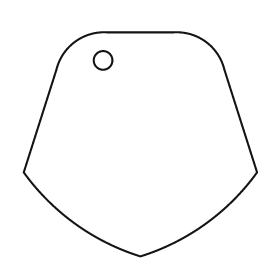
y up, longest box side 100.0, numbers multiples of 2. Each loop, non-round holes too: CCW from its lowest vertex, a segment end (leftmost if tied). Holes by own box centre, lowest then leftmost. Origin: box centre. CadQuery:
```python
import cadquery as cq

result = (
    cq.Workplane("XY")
    .moveTo(0.0, -48.0)
    .threePointArc((28.0, -34.0), (50.0, -12.0))
    .lineTo(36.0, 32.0)
    .threePointArc((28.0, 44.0), (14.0, 48.0))
    .lineTo(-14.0, 48.0)
    .threePointArc((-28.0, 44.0), (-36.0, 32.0))
    .lineTo(-50.0, -12.0)
    .threePointArc((-28.0, -34.0), (0.0, -48.0))
    .close()
    .moveTo(-16.0, 36.0)
    .circle(4.0)
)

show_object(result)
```